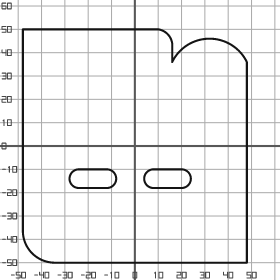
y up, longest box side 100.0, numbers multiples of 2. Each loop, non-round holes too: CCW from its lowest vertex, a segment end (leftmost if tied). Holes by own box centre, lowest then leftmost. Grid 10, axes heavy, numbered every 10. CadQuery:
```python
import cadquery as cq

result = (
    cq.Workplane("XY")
    .moveTo(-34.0, -50.0)
    .lineTo(48.0, -50.0)
    .lineTo(48.0, 36.0)
    .threePointArc((32.0, 46.0), (16.0, 36.0))
    .lineTo(16.0, 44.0)
    .threePointArc((14.0, 48.0), (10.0, 50.0))
    .lineTo(-48.0, 50.0)
    .lineTo(-48.0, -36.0)
    .threePointArc((-44.0, -46.0), (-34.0, -50.0))
    .close()
    .moveTo(-24.0, -18.0)
    .lineTo(-12.0, -18.0)
    .threePointArc((-8.0, -14.0), (-12.0, -10.0))
    .lineTo(-24.0, -10.0)
    .threePointArc((-28.0, -14.0), (-24.0, -18.0))
    .close()
    .moveTo(8.0, -18.0)
    .lineTo(20.0, -18.0)
    .threePointArc((24.0, -14.0), (20.0, -10.0))
    .lineTo(8.0, -10.0)
    .threePointArc((4.0, -14.0), (8.0, -18.0))
    .close()
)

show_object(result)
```